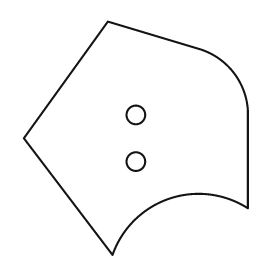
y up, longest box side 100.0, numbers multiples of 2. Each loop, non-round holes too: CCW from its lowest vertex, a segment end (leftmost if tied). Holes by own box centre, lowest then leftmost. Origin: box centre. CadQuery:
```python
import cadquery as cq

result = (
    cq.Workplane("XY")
    .moveTo(-10.0, -50.0)
    .threePointArc((14.0, -26.0), (48.0, -30.0))
    .lineTo(48.0, 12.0)
    .threePointArc((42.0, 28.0), (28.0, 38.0))
    .lineTo(-12.0, 50.0)
    .lineTo(-48.0, 0.0)
    .close()
    .moveTo(0.0, -10.0)
    .circle(4.0)
    .moveTo(0.0, 10.0)
    .circle(4.0)
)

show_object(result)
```